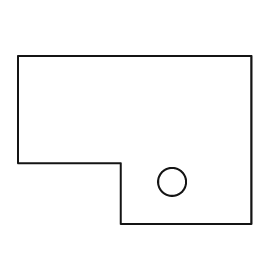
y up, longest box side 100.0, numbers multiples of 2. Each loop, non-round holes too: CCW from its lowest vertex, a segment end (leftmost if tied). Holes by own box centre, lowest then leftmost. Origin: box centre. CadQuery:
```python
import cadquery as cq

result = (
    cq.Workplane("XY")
    .moveTo(-6.0, -36.0)
    .lineTo(50.0, -36.0)
    .lineTo(50.0, 36.0)
    .lineTo(-50.0, 36.0)
    .lineTo(-50.0, -10.0)
    .lineTo(-6.0, -10.0)
    .close()
    .moveTo(16.0, -18.0)
    .circle(6.0)
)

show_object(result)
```